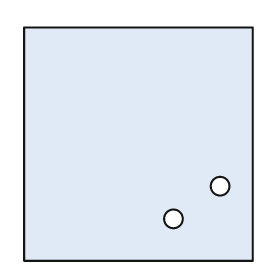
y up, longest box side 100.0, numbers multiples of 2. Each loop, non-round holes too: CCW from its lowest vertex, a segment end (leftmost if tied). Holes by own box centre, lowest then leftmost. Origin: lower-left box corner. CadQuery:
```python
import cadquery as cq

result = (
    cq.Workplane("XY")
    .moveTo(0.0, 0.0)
    .lineTo(98.0, 0.0)
    .lineTo(98.0, 100.0)
    .lineTo(0.0, 100.0)
    .close()
    .moveTo(64.0, 18.0)
    .circle(4.0)
    .moveTo(84.0, 32.0)
    .circle(4.0)
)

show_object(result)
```